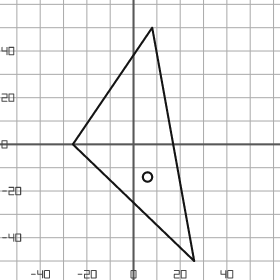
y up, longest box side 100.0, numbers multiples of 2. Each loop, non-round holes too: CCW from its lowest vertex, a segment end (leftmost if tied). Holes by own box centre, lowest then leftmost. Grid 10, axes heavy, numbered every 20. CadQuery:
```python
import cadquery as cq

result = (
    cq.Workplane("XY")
    .moveTo(26.0, -50.0)
    .lineTo(8.0, 50.0)
    .lineTo(-26.0, 0.0)
    .close()
    .moveTo(6.0, -14.0)
    .circle(2.0)
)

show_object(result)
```